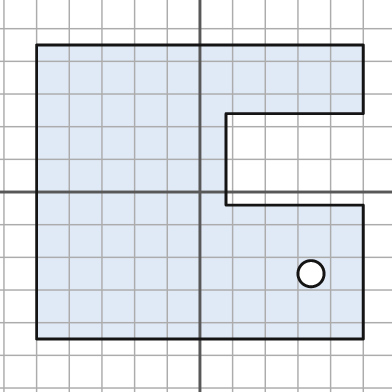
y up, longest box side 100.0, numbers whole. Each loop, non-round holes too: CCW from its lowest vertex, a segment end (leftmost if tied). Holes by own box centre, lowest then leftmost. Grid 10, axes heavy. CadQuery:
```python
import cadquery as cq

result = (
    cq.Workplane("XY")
    .moveTo(-50.0, -45.0)
    .lineTo(50.0, -45.0)
    .lineTo(50.0, -4.0)
    .lineTo(8.0, -4.0)
    .lineTo(8.0, 24.0)
    .lineTo(50.0, 24.0)
    .lineTo(50.0, 45.0)
    .lineTo(-50.0, 45.0)
    .close()
    .moveTo(34.0, -25.0)
    .circle(4.0)
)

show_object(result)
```